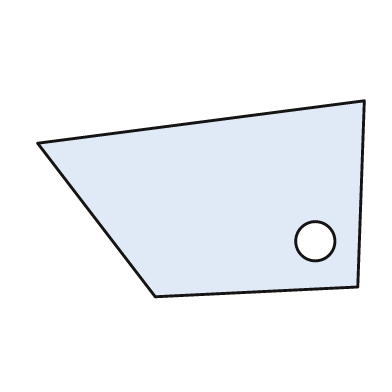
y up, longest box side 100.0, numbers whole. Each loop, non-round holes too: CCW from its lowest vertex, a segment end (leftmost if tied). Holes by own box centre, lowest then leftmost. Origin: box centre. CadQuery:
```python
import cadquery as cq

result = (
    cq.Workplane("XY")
    .moveTo(-14.0, -30.0)
    .lineTo(48.0, -27.0)
    .lineTo(50.0, 30.0)
    .lineTo(-50.0, 17.0)
    .close()
    .moveTo(35.0, -13.0)
    .circle(6.0)
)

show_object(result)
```